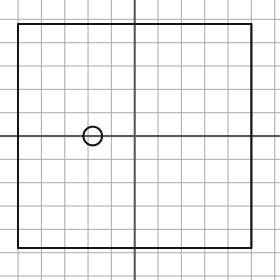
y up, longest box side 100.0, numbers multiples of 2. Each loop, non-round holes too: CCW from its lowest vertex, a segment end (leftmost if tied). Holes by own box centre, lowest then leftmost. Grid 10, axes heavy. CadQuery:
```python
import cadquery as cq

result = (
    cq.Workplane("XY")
    .moveTo(-50.0, -48.0)
    .lineTo(50.0, -48.0)
    .lineTo(50.0, 48.0)
    .lineTo(-50.0, 48.0)
    .close()
    .moveTo(-18.0, 0.0)
    .circle(4.0)
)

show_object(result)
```